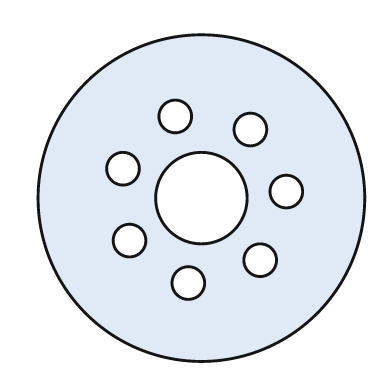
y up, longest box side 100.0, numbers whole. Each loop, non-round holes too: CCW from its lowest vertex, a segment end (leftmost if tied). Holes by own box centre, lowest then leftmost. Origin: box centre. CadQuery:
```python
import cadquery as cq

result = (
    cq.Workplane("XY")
    .moveTo(0.0, 0.0)
    .circle(50.0)
    .moveTo(-4.0, -26.0)
    .circle(5.0)
    .moveTo(18.0, -19.0)
    .circle(5.0)
    .moveTo(-22.0, -13.0)
    .circle(5.0)
    .moveTo(0.0, 0.0)
    .circle(14.0)
    .moveTo(26.0, 2.0)
    .circle(5.0)
    .moveTo(-24.0, 9.0)
    .circle(5.0)
    .moveTo(15.0, 21.0)
    .circle(5.0)
    .moveTo(-8.0, 25.0)
    .circle(5.0)
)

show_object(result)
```